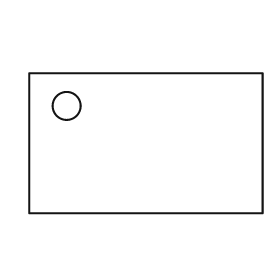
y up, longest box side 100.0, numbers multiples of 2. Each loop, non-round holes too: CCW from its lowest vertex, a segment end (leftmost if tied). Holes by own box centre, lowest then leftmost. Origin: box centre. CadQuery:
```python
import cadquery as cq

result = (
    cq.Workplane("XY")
    .moveTo(-50.0, -30.0)
    .lineTo(50.0, -30.0)
    .lineTo(50.0, 30.0)
    .lineTo(-50.0, 30.0)
    .close()
    .moveTo(-34.0, 16.0)
    .circle(6.0)
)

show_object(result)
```